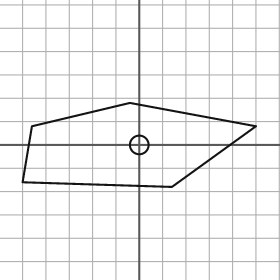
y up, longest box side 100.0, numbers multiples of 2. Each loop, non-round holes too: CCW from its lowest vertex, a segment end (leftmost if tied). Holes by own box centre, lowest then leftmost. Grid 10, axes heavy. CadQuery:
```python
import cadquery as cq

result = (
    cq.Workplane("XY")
    .moveTo(14.0, -18.0)
    .lineTo(50.0, 8.0)
    .lineTo(-4.0, 18.0)
    .lineTo(-46.0, 8.0)
    .lineTo(-50.0, -16.0)
    .close()
    .moveTo(0.0, 0.0)
    .circle(4.0)
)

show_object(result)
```